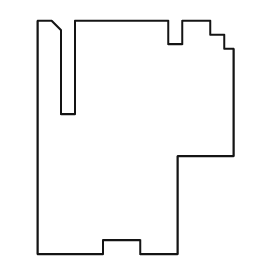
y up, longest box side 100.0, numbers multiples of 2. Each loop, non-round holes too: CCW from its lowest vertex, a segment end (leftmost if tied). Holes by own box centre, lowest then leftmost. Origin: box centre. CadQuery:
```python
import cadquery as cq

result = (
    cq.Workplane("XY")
    .moveTo(-42.0, -50.0)
    .lineTo(-14.0, -50.0)
    .lineTo(-14.0, -44.0)
    .lineTo(2.0, -44.0)
    .lineTo(2.0, -50.0)
    .lineTo(18.0, -50.0)
    .lineTo(18.0, -8.0)
    .lineTo(42.0, -8.0)
    .lineTo(42.0, 38.0)
    .lineTo(38.0, 38.0)
    .lineTo(38.0, 44.0)
    .lineTo(32.0, 44.0)
    .lineTo(32.0, 50.0)
    .lineTo(20.0, 50.0)
    .lineTo(20.0, 40.0)
    .lineTo(14.0, 40.0)
    .lineTo(14.0, 50.0)
    .lineTo(-26.0, 50.0)
    .lineTo(-26.0, 10.0)
    .lineTo(-32.0, 10.0)
    .lineTo(-32.0, 46.0)
    .lineTo(-36.0, 50.0)
    .lineTo(-42.0, 50.0)
    .close()
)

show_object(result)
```